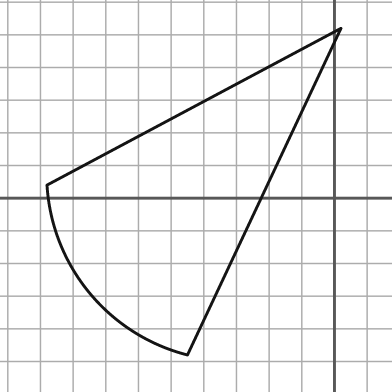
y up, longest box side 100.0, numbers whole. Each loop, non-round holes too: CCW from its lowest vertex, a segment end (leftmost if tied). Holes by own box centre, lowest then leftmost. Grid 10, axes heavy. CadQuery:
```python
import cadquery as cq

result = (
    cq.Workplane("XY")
    .moveTo(-45.0, -48.0)
    .lineTo(2.0, 52.0)
    .lineTo(-88.0, 4.0)
    .threePointArc((-75.0, -29.0), (-45.0, -48.0))
    .close()
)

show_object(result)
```